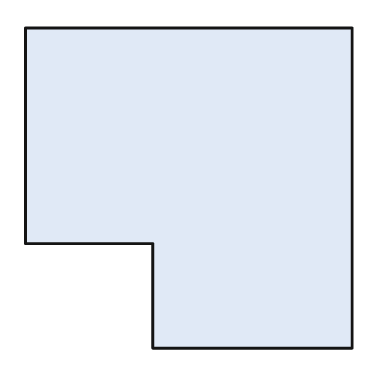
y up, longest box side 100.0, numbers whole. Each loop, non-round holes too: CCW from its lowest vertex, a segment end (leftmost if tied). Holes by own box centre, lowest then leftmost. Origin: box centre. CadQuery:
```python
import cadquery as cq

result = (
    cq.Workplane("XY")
    .moveTo(-11.0, -49.0)
    .lineTo(50.0, -49.0)
    .lineTo(50.0, 49.0)
    .lineTo(-50.0, 49.0)
    .lineTo(-50.0, -17.0)
    .lineTo(-11.0, -17.0)
    .close()
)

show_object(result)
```